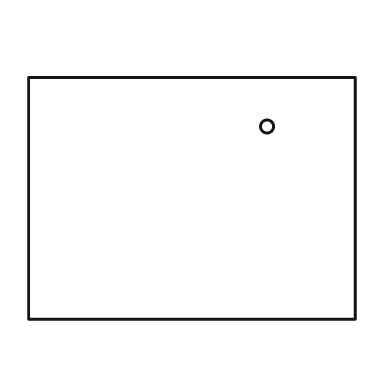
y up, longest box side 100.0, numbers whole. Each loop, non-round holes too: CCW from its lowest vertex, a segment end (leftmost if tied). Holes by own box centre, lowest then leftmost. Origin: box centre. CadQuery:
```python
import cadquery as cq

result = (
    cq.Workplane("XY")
    .moveTo(-50.0, -37.0)
    .lineTo(50.0, -37.0)
    .lineTo(50.0, 37.0)
    .lineTo(-50.0, 37.0)
    .close()
    .moveTo(23.0, 22.0)
    .circle(2.0)
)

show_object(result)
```